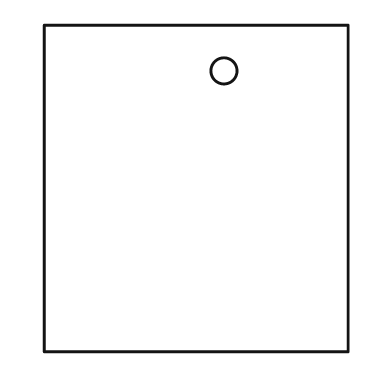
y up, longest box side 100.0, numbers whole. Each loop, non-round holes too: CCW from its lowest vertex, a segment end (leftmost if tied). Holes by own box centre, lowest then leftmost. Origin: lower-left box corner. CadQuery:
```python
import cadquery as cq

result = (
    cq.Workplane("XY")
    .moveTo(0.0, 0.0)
    .lineTo(93.0, 0.0)
    .lineTo(93.0, 100.0)
    .lineTo(0.0, 100.0)
    .close()
    .moveTo(55.0, 86.0)
    .circle(4.0)
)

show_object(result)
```